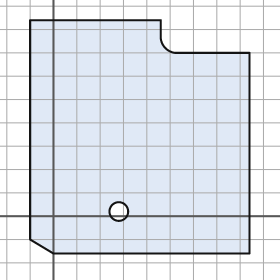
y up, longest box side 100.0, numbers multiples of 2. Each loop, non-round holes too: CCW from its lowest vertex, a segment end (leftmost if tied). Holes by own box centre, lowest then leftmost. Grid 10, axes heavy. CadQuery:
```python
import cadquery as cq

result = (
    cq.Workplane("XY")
    .moveTo(0.0, -16.0)
    .lineTo(84.0, -16.0)
    .lineTo(84.0, 70.0)
    .lineTo(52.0, 70.0)
    .threePointArc((48.0, 72.0), (46.0, 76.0))
    .lineTo(46.0, 84.0)
    .lineTo(-10.0, 84.0)
    .lineTo(-10.0, -10.0)
    .close()
    .moveTo(28.0, 2.0)
    .circle(4.0)
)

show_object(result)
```